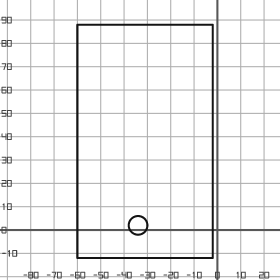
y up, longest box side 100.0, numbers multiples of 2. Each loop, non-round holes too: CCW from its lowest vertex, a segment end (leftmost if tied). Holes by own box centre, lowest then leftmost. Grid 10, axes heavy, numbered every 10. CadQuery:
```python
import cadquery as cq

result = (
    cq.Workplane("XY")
    .moveTo(-60.0, -12.0)
    .lineTo(-2.0, -12.0)
    .lineTo(-2.0, 88.0)
    .lineTo(-60.0, 88.0)
    .close()
    .moveTo(-34.0, 2.0)
    .circle(4.0)
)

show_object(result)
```